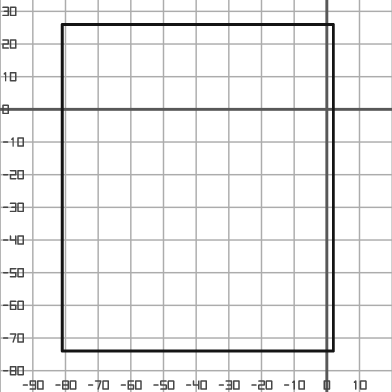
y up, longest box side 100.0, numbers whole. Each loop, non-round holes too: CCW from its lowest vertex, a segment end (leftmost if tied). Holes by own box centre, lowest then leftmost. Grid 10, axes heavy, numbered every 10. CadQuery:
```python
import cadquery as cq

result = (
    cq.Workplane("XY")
    .moveTo(-81.0, -74.0)
    .lineTo(2.0, -74.0)
    .lineTo(2.0, 26.0)
    .lineTo(-81.0, 26.0)
    .close()
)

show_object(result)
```